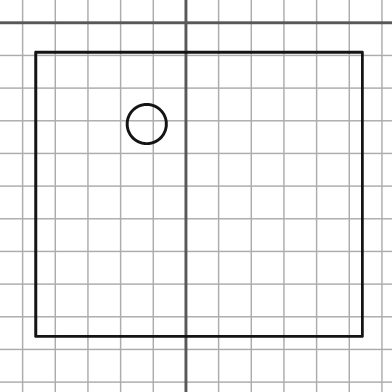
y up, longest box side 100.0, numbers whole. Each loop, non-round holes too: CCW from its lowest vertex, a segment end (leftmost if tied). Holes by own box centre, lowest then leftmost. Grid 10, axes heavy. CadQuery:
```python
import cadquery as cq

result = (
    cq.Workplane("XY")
    .moveTo(-46.0, -96.0)
    .lineTo(54.0, -96.0)
    .lineTo(54.0, -9.0)
    .lineTo(-46.0, -9.0)
    .close()
    .moveTo(-12.0, -31.0)
    .circle(6.0)
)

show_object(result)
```